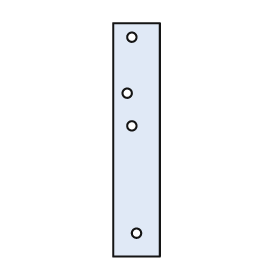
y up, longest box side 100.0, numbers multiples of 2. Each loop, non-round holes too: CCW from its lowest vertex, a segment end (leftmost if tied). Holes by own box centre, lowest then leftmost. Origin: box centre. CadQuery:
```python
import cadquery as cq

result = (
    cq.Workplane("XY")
    .moveTo(-10.0, -50.0)
    .lineTo(10.0, -50.0)
    .lineTo(10.0, 50.0)
    .lineTo(-10.0, 50.0)
    .close()
    .moveTo(0.0, -40.0)
    .circle(2.0)
    .moveTo(-2.0, 6.0)
    .circle(2.0)
    .moveTo(-4.0, 20.0)
    .circle(2.0)
    .moveTo(-2.0, 44.0)
    .circle(2.0)
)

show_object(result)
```